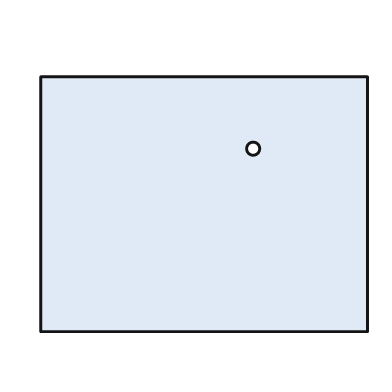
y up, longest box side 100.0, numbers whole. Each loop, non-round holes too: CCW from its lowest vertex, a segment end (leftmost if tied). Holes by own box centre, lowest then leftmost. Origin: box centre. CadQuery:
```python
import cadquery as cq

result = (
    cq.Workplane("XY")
    .moveTo(-50.0, -39.0)
    .lineTo(50.0, -39.0)
    .lineTo(50.0, 39.0)
    .lineTo(-50.0, 39.0)
    .close()
    .moveTo(15.0, 17.0)
    .circle(2.0)
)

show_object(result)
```